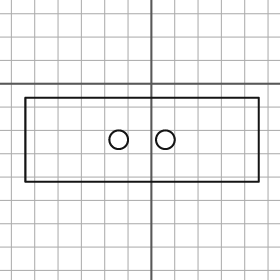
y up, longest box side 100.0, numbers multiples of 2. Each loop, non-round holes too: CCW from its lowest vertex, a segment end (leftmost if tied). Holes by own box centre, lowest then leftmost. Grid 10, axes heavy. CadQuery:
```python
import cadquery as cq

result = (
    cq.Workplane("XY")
    .moveTo(-54.0, -42.0)
    .lineTo(46.0, -42.0)
    .lineTo(46.0, -6.0)
    .lineTo(-54.0, -6.0)
    .close()
    .moveTo(-14.0, -24.0)
    .circle(4.0)
    .moveTo(6.0, -24.0)
    .circle(4.0)
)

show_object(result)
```